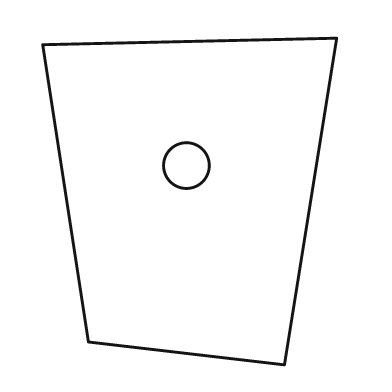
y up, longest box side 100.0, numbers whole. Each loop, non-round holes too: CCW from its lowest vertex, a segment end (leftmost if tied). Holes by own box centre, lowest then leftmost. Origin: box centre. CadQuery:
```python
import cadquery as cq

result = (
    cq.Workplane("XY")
    .moveTo(29.0, -50.0)
    .lineTo(45.0, 50.0)
    .lineTo(-45.0, 48.0)
    .lineTo(-31.0, -43.0)
    .close()
    .moveTo(-1.0, 11.0)
    .circle(7.0)
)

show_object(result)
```